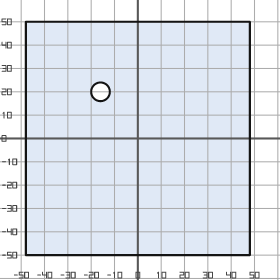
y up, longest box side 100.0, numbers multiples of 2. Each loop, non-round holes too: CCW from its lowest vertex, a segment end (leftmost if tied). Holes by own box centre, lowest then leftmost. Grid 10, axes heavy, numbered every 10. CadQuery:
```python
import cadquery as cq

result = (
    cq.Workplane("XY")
    .moveTo(-48.0, -50.0)
    .lineTo(48.0, -50.0)
    .lineTo(48.0, 50.0)
    .lineTo(-48.0, 50.0)
    .close()
    .moveTo(-16.0, 20.0)
    .circle(4.0)
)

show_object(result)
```